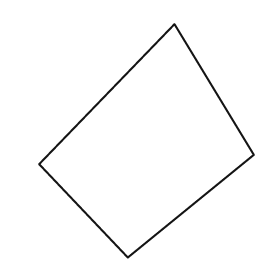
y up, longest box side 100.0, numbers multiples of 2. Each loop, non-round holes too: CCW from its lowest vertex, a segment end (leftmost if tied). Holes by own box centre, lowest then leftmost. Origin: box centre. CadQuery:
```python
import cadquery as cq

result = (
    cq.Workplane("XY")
    .moveTo(-8.0, -50.0)
    .lineTo(46.0, -6.0)
    .lineTo(12.0, 50.0)
    .lineTo(-46.0, -10.0)
    .close()
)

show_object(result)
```